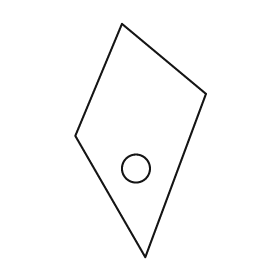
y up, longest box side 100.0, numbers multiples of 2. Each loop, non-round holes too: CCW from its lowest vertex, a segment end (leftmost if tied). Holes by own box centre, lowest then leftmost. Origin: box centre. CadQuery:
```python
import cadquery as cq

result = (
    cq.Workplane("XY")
    .moveTo(2.0, -50.0)
    .lineTo(28.0, 20.0)
    .lineTo(-8.0, 50.0)
    .lineTo(-28.0, 2.0)
    .close()
    .moveTo(-2.0, -12.0)
    .circle(6.0)
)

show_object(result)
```